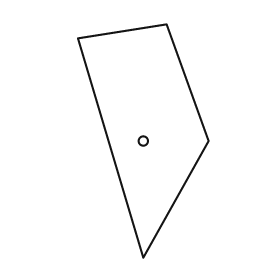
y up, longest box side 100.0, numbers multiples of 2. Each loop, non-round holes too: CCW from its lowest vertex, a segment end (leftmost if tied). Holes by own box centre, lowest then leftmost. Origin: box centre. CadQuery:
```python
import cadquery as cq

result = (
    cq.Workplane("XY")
    .moveTo(0.0, -50.0)
    .lineTo(28.0, 0.0)
    .lineTo(10.0, 50.0)
    .lineTo(-28.0, 44.0)
    .close()
    .moveTo(0.0, 0.0)
    .circle(2.0)
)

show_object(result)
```